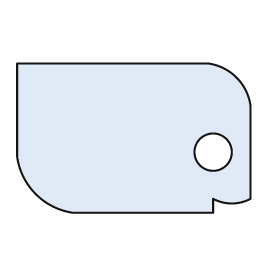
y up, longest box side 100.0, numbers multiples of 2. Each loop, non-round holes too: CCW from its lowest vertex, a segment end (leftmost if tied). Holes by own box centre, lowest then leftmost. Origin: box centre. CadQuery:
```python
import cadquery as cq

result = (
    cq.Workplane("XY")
    .moveTo(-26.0, -32.0)
    .lineTo(34.0, -32.0)
    .lineTo(34.0, -26.0)
    .threePointArc((42.0, -28.0), (50.0, -26.0))
    .lineTo(50.0, 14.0)
    .threePointArc((44.0, 26.0), (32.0, 32.0))
    .lineTo(-50.0, 32.0)
    .lineTo(-50.0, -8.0)
    .threePointArc((-42.0, -24.0), (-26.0, -32.0))
    .close()
    .moveTo(34.0, -6.0)
    .circle(8.0)
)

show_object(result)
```